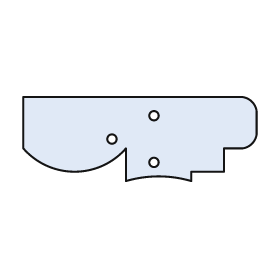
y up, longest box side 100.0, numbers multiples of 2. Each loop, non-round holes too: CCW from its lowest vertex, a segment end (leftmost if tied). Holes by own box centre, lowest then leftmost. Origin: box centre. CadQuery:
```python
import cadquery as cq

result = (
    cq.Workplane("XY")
    .moveTo(-6.0, -18.0)
    .threePointArc((8.0, -16.0), (22.0, -18.0))
    .lineTo(22.0, -14.0)
    .lineTo(36.0, -14.0)
    .lineTo(36.0, -4.0)
    .lineTo(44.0, -4.0)
    .threePointArc((48.0, -2.0), (50.0, 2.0))
    .lineTo(50.0, 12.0)
    .threePointArc((48.0, 16.0), (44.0, 18.0))
    .lineTo(-50.0, 18.0)
    .lineTo(-50.0, -4.0)
    .threePointArc((-28.0, -14.0), (-6.0, -4.0))
    .close()
    .moveTo(6.0, -10.0)
    .circle(2.0)
    .moveTo(-12.0, 0.0)
    .circle(2.0)
    .moveTo(6.0, 10.0)
    .circle(2.0)
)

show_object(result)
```